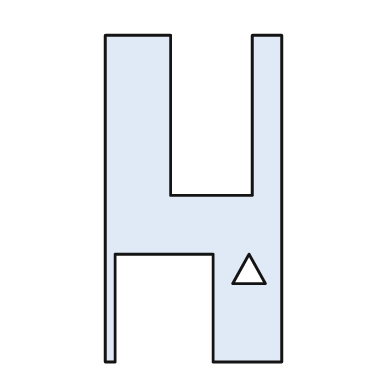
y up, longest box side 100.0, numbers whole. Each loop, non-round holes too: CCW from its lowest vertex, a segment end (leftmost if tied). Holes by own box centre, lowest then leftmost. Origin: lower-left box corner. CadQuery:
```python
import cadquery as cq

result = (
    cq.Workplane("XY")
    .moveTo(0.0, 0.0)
    .lineTo(3.0, 0.0)
    .lineTo(3.0, 33.0)
    .lineTo(33.0, 33.0)
    .lineTo(33.0, 0.0)
    .lineTo(54.0, 0.0)
    .lineTo(54.0, 100.0)
    .lineTo(45.0, 100.0)
    .lineTo(45.0, 51.0)
    .lineTo(20.0, 51.0)
    .lineTo(20.0, 100.0)
    .lineTo(0.0, 100.0)
    .close()
    .moveTo(39.0, 24.0)
    .lineTo(49.0, 24.0)
    .lineTo(44.0, 33.0)
    .close()
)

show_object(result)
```